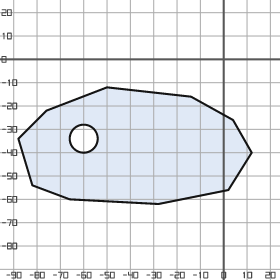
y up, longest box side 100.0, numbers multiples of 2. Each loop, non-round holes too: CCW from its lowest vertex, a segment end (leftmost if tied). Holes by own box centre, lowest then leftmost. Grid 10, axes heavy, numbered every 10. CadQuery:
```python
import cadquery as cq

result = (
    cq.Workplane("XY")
    .moveTo(-28.0, -62.0)
    .lineTo(2.0, -56.0)
    .lineTo(12.0, -40.0)
    .lineTo(4.0, -26.0)
    .lineTo(-14.0, -16.0)
    .lineTo(-50.0, -12.0)
    .lineTo(-76.0, -22.0)
    .lineTo(-88.0, -34.0)
    .lineTo(-82.0, -54.0)
    .lineTo(-66.0, -60.0)
    .close()
    .moveTo(-60.0, -34.0)
    .circle(6.0)
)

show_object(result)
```